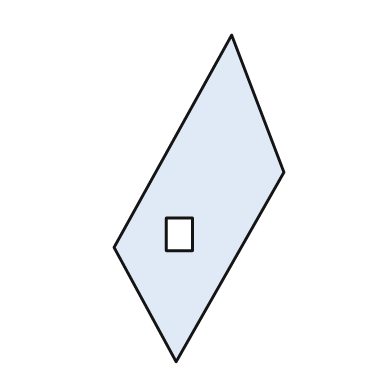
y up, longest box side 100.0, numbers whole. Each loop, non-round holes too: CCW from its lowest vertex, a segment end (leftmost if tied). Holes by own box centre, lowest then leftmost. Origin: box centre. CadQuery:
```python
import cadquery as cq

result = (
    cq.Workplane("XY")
    .moveTo(-7.0, -50.0)
    .lineTo(26.0, 8.0)
    .lineTo(10.0, 50.0)
    .lineTo(-26.0, -15.0)
    .close()
    .moveTo(-10.0, -16.0)
    .lineTo(-2.0, -16.0)
    .lineTo(-2.0, -6.0)
    .lineTo(-10.0, -6.0)
    .close()
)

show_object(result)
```